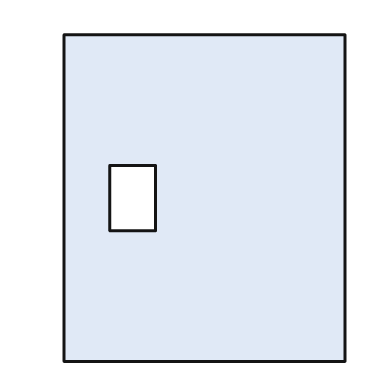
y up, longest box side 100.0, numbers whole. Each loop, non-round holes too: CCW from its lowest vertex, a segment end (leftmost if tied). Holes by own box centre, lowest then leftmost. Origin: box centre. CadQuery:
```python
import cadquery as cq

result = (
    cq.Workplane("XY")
    .moveTo(-43.0, -50.0)
    .lineTo(43.0, -50.0)
    .lineTo(43.0, 50.0)
    .lineTo(-43.0, 50.0)
    .close()
    .moveTo(-29.0, -10.0)
    .lineTo(-15.0, -10.0)
    .lineTo(-15.0, 10.0)
    .lineTo(-29.0, 10.0)
    .close()
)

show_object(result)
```